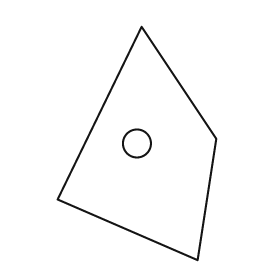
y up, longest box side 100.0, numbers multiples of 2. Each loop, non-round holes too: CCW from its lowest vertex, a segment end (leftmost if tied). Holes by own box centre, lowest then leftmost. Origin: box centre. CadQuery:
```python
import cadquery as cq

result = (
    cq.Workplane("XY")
    .moveTo(26.0, -50.0)
    .lineTo(34.0, 2.0)
    .lineTo(2.0, 50.0)
    .lineTo(-34.0, -24.0)
    .close()
    .moveTo(0.0, 0.0)
    .circle(6.0)
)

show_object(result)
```